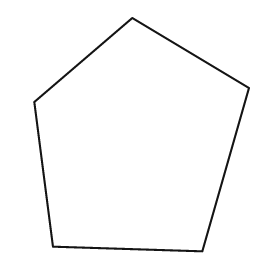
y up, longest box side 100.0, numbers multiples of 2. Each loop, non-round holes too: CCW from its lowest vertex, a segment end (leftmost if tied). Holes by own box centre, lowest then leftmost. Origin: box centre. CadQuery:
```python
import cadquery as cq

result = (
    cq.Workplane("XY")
    .moveTo(26.0, -50.0)
    .lineTo(46.0, 20.0)
    .lineTo(-4.0, 50.0)
    .lineTo(-46.0, 14.0)
    .lineTo(-38.0, -48.0)
    .close()
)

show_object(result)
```